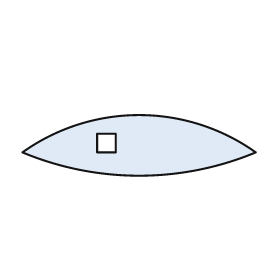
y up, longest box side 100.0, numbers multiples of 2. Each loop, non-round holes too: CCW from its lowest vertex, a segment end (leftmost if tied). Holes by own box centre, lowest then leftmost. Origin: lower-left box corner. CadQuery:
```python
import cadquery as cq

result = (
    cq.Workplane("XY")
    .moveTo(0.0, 10.0)
    .threePointArc((50.0, 0.0), (100.0, 10.0))
    .threePointArc((50.0, 26.0), (0.0, 10.0))
    .close()
    .moveTo(32.0, 10.0)
    .lineTo(40.0, 10.0)
    .lineTo(40.0, 18.0)
    .lineTo(32.0, 18.0)
    .close()
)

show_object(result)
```